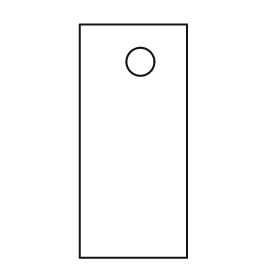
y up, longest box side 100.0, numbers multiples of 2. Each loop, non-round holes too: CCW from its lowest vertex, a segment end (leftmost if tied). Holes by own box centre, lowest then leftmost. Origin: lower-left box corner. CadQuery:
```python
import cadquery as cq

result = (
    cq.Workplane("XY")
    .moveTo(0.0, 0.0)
    .lineTo(46.0, 0.0)
    .lineTo(46.0, 100.0)
    .lineTo(0.0, 100.0)
    .close()
    .moveTo(26.0, 84.0)
    .circle(6.0)
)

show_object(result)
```